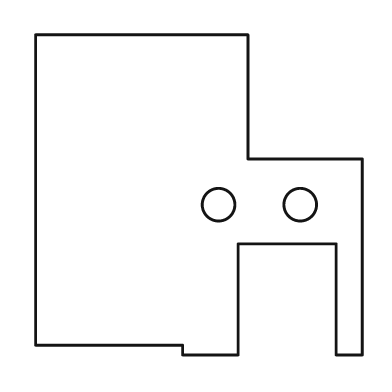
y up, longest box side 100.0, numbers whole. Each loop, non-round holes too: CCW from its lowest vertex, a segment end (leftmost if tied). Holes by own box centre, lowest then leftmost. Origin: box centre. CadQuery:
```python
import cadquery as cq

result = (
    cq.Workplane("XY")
    .moveTo(-5.0, -49.0)
    .lineTo(12.0, -49.0)
    .lineTo(12.0, -15.0)
    .lineTo(42.0, -15.0)
    .lineTo(42.0, -49.0)
    .lineTo(50.0, -49.0)
    .lineTo(50.0, 11.0)
    .lineTo(15.0, 11.0)
    .lineTo(15.0, 49.0)
    .lineTo(-50.0, 49.0)
    .lineTo(-50.0, -46.0)
    .lineTo(-5.0, -46.0)
    .close()
    .moveTo(6.0, -3.0)
    .circle(5.0)
    .moveTo(31.0, -3.0)
    .circle(5.0)
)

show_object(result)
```